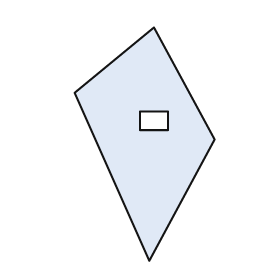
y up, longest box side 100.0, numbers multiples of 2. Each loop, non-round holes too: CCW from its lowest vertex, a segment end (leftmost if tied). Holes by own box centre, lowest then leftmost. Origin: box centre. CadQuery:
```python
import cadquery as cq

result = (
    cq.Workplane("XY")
    .moveTo(2.0, -50.0)
    .lineTo(30.0, 2.0)
    .lineTo(4.0, 50.0)
    .lineTo(-30.0, 22.0)
    .close()
    .moveTo(-2.0, 6.0)
    .lineTo(10.0, 6.0)
    .lineTo(10.0, 14.0)
    .lineTo(-2.0, 14.0)
    .close()
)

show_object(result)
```